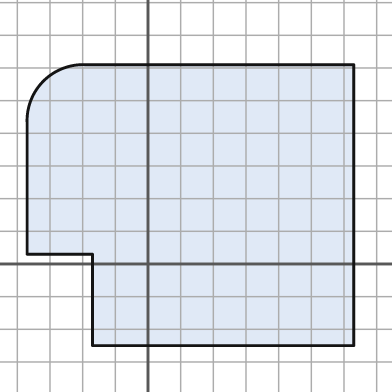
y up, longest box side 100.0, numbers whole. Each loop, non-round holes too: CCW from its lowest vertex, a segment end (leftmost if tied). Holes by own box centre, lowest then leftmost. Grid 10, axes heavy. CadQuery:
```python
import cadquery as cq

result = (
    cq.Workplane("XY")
    .moveTo(-17.0, -25.0)
    .lineTo(63.0, -25.0)
    .lineTo(63.0, 61.0)
    .lineTo(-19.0, 61.0)
    .threePointArc((-32.0, 56.0), (-37.0, 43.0))
    .lineTo(-37.0, 3.0)
    .lineTo(-17.0, 3.0)
    .close()
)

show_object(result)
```